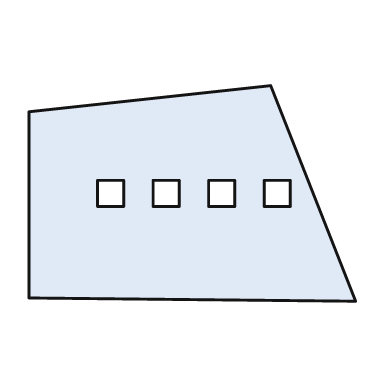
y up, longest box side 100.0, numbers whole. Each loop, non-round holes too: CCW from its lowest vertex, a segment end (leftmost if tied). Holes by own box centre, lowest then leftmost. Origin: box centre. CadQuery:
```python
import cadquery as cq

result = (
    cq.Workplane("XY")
    .moveTo(50.0, -33.0)
    .lineTo(24.0, 33.0)
    .lineTo(-50.0, 25.0)
    .lineTo(-50.0, -32.0)
    .close()
    .moveTo(-29.0, -4.0)
    .lineTo(-21.0, -4.0)
    .lineTo(-21.0, 4.0)
    .lineTo(-29.0, 4.0)
    .close()
    .moveTo(-12.0, -4.0)
    .lineTo(-4.0, -4.0)
    .lineTo(-4.0, 4.0)
    .lineTo(-12.0, 4.0)
    .close()
    .moveTo(5.0, -4.0)
    .lineTo(13.0, -4.0)
    .lineTo(13.0, 4.0)
    .lineTo(5.0, 4.0)
    .close()
    .moveTo(22.0, -4.0)
    .lineTo(30.0, -4.0)
    .lineTo(30.0, 4.0)
    .lineTo(22.0, 4.0)
    .close()
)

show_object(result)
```